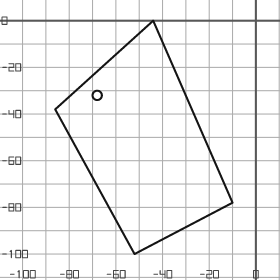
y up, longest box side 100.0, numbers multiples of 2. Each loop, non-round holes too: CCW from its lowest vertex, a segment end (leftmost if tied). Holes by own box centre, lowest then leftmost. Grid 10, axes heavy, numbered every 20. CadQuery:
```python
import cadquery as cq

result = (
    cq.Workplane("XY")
    .moveTo(-52.0, -100.0)
    .lineTo(-10.0, -78.0)
    .lineTo(-44.0, 0.0)
    .lineTo(-86.0, -38.0)
    .close()
    .moveTo(-68.0, -32.0)
    .circle(2.0)
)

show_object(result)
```